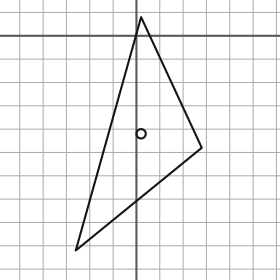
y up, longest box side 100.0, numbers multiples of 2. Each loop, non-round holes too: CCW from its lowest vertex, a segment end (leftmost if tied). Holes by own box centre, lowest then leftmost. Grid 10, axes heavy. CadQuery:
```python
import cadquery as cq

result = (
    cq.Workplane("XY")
    .moveTo(-26.0, -92.0)
    .lineTo(28.0, -48.0)
    .lineTo(2.0, 8.0)
    .close()
    .moveTo(2.0, -42.0)
    .circle(2.0)
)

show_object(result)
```